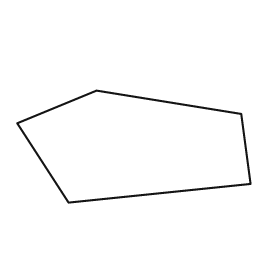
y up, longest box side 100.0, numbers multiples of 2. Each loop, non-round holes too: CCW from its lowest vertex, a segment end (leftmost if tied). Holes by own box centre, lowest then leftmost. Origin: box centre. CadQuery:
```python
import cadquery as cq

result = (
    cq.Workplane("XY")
    .moveTo(-28.0, -24.0)
    .lineTo(50.0, -16.0)
    .lineTo(46.0, 14.0)
    .lineTo(-16.0, 24.0)
    .lineTo(-50.0, 10.0)
    .close()
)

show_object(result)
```